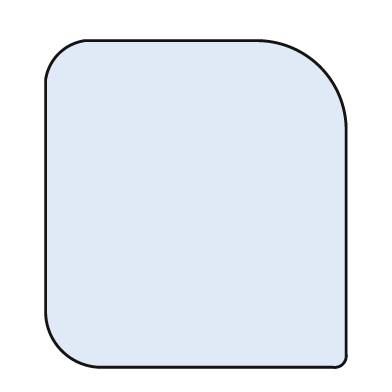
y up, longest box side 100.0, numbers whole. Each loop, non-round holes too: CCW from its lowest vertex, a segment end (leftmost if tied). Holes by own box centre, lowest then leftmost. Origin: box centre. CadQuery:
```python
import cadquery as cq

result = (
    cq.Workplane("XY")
    .moveTo(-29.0, -50.0)
    .lineTo(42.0, -50.0)
    .threePointArc((45.0, -49.0), (46.0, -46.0))
    .lineTo(46.0, 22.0)
    .threePointArc((38.0, 42.0), (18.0, 50.0))
    .lineTo(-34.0, 50.0)
    .threePointArc((-42.0, 46.0), (-46.0, 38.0))
    .lineTo(-46.0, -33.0)
    .threePointArc((-41.0, -45.0), (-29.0, -50.0))
    .close()
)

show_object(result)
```